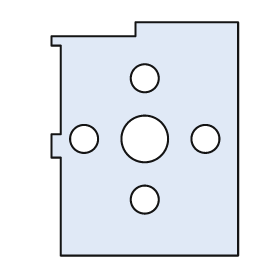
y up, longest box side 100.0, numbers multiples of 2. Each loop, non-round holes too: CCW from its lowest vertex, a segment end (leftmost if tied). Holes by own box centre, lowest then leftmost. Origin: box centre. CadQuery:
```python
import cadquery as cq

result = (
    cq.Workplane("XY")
    .moveTo(-36.0, -50.0)
    .lineTo(40.0, -50.0)
    .lineTo(40.0, 50.0)
    .lineTo(-4.0, 50.0)
    .lineTo(-4.0, 44.0)
    .lineTo(-40.0, 44.0)
    .lineTo(-40.0, 40.0)
    .lineTo(-36.0, 40.0)
    .lineTo(-36.0, 2.0)
    .lineTo(-40.0, 2.0)
    .lineTo(-40.0, -8.0)
    .lineTo(-36.0, -8.0)
    .close()
    .moveTo(0.0, -26.0)
    .circle(6.0)
    .moveTo(-26.0, 0.0)
    .circle(6.0)
    .moveTo(0.0, 0.0)
    .circle(10.0)
    .moveTo(26.0, 0.0)
    .circle(6.0)
    .moveTo(0.0, 26.0)
    .circle(6.0)
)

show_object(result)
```